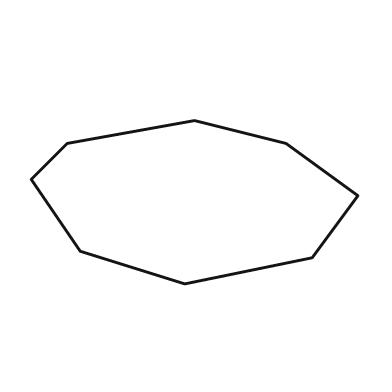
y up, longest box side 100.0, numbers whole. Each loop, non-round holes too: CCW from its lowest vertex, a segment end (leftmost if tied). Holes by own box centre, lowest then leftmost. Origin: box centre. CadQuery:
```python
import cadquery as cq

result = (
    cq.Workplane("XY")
    .moveTo(-3.0, -25.0)
    .lineTo(36.0, -17.0)
    .lineTo(50.0, 2.0)
    .lineTo(28.0, 18.0)
    .lineTo(0.0, 25.0)
    .lineTo(-39.0, 18.0)
    .lineTo(-50.0, 7.0)
    .lineTo(-35.0, -15.0)
    .close()
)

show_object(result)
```